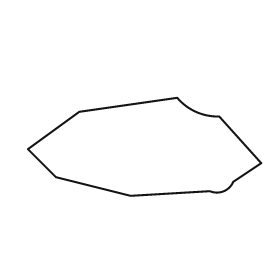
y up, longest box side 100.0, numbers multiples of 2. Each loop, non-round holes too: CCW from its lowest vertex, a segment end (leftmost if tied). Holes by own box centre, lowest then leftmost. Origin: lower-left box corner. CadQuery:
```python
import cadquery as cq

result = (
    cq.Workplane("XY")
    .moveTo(44.0, 0.0)
    .lineTo(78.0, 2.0)
    .threePointArc((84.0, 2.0), (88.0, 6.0))
    .lineTo(100.0, 14.0)
    .lineTo(82.0, 34.0)
    .threePointArc((72.0, 36.0), (64.0, 42.0))
    .lineTo(22.0, 36.0)
    .lineTo(0.0, 20.0)
    .lineTo(12.0, 8.0)
    .close()
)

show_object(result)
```